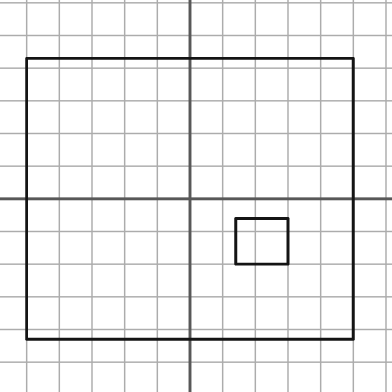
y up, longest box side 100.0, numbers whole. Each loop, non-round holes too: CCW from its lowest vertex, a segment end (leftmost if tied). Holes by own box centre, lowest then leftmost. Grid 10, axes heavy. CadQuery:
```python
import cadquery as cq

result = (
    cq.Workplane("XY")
    .moveTo(-50.0, -43.0)
    .lineTo(50.0, -43.0)
    .lineTo(50.0, 43.0)
    .lineTo(-50.0, 43.0)
    .close()
    .moveTo(14.0, -20.0)
    .lineTo(30.0, -20.0)
    .lineTo(30.0, -6.0)
    .lineTo(14.0, -6.0)
    .close()
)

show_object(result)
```